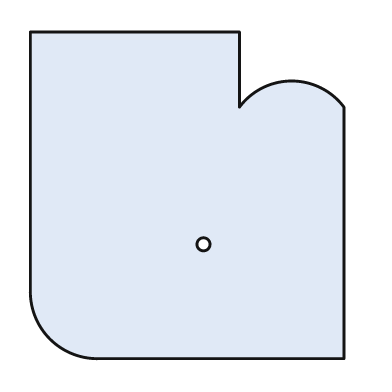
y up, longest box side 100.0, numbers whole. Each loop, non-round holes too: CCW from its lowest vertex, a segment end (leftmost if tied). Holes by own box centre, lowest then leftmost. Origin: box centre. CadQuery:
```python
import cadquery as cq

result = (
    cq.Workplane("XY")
    .moveTo(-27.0, -50.0)
    .lineTo(48.0, -50.0)
    .lineTo(48.0, 27.0)
    .threePointArc((32.0, 35.0), (16.0, 27.0))
    .lineTo(16.0, 50.0)
    .lineTo(-48.0, 50.0)
    .lineTo(-48.0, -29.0)
    .threePointArc((-42.0, -44.0), (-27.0, -50.0))
    .close()
    .moveTo(5.0, -15.0)
    .circle(2.0)
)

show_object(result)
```